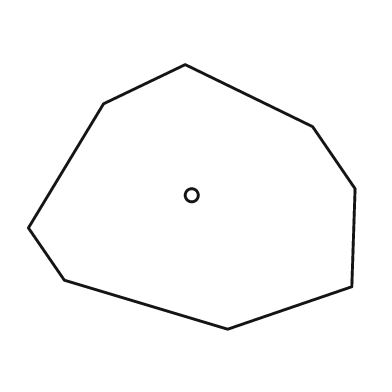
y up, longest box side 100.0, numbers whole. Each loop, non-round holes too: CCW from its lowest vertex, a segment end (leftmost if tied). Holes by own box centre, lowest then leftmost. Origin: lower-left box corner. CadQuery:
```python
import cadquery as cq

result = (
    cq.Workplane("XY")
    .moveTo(61.0, 0.0)
    .lineTo(99.0, 13.0)
    .lineTo(100.0, 43.0)
    .lineTo(87.0, 62.0)
    .lineTo(48.0, 81.0)
    .lineTo(23.0, 69.0)
    .lineTo(0.0, 31.0)
    .lineTo(11.0, 15.0)
    .close()
    .moveTo(50.0, 41.0)
    .circle(2.0)
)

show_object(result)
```